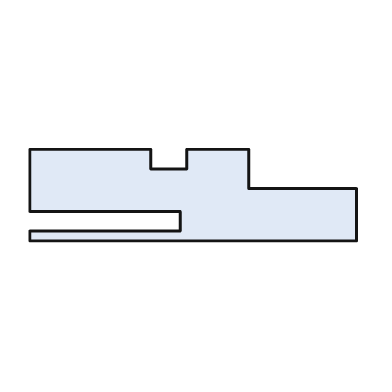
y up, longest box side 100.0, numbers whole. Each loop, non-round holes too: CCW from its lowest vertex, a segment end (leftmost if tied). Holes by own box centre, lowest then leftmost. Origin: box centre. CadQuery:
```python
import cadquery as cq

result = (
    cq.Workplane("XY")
    .moveTo(-50.0, -14.0)
    .lineTo(50.0, -14.0)
    .lineTo(50.0, 2.0)
    .lineTo(17.0, 2.0)
    .lineTo(17.0, 14.0)
    .lineTo(-2.0, 14.0)
    .lineTo(-2.0, 8.0)
    .lineTo(-13.0, 8.0)
    .lineTo(-13.0, 14.0)
    .lineTo(-50.0, 14.0)
    .lineTo(-50.0, -5.0)
    .lineTo(-4.0, -5.0)
    .lineTo(-4.0, -11.0)
    .lineTo(-50.0, -11.0)
    .close()
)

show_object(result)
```